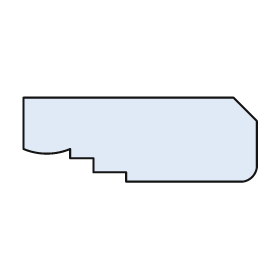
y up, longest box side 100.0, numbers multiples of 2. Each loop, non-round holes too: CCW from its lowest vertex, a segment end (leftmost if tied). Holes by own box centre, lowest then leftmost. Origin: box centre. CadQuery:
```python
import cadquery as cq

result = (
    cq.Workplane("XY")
    .moveTo(-6.0, -18.0)
    .lineTo(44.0, -18.0)
    .threePointArc((48.0, -16.0), (50.0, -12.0))
    .lineTo(50.0, 8.0)
    .lineTo(40.0, 18.0)
    .lineTo(-50.0, 18.0)
    .lineTo(-50.0, -4.0)
    .threePointArc((-40.0, -6.0), (-30.0, -4.0))
    .lineTo(-30.0, -8.0)
    .lineTo(-20.0, -8.0)
    .lineTo(-20.0, -14.0)
    .lineTo(-6.0, -14.0)
    .close()
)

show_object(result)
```